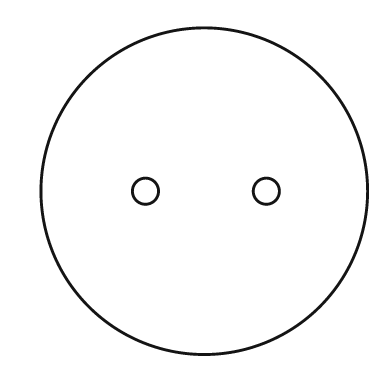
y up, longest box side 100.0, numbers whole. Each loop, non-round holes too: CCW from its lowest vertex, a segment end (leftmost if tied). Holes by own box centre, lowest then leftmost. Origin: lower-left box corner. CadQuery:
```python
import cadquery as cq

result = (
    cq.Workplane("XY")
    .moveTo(50.0, 50.0)
    .circle(50.0)
    .moveTo(32.0, 50.0)
    .circle(4.0)
    .moveTo(69.0, 50.0)
    .circle(4.0)
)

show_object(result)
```